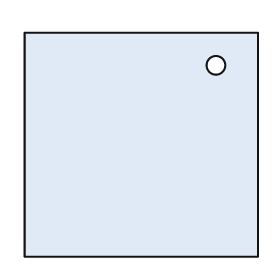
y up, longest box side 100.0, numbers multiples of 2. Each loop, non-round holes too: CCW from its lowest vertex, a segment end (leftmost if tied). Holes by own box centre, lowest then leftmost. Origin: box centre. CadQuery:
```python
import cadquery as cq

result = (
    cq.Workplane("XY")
    .moveTo(-50.0, -48.0)
    .lineTo(50.0, -48.0)
    .lineTo(50.0, 48.0)
    .lineTo(-50.0, 48.0)
    .close()
    .moveTo(32.0, 34.0)
    .circle(4.0)
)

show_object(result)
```